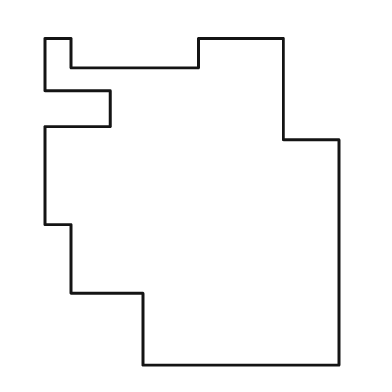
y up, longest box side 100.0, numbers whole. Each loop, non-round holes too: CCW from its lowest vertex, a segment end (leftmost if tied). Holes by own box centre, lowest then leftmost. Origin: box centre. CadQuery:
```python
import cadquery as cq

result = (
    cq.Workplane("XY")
    .moveTo(-15.0, -50.0)
    .lineTo(45.0, -50.0)
    .lineTo(45.0, 19.0)
    .lineTo(28.0, 19.0)
    .lineTo(28.0, 50.0)
    .lineTo(2.0, 50.0)
    .lineTo(2.0, 41.0)
    .lineTo(-37.0, 41.0)
    .lineTo(-37.0, 50.0)
    .lineTo(-45.0, 50.0)
    .lineTo(-45.0, 34.0)
    .lineTo(-25.0, 34.0)
    .lineTo(-25.0, 23.0)
    .lineTo(-45.0, 23.0)
    .lineTo(-45.0, -7.0)
    .lineTo(-37.0, -7.0)
    .lineTo(-37.0, -28.0)
    .lineTo(-15.0, -28.0)
    .close()
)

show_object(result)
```